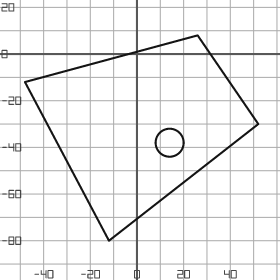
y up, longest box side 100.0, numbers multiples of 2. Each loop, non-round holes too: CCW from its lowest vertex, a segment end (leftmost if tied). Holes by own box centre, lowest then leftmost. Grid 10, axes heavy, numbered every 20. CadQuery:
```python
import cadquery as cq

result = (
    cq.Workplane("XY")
    .moveTo(-12.0, -80.0)
    .lineTo(52.0, -30.0)
    .lineTo(26.0, 8.0)
    .lineTo(-48.0, -12.0)
    .close()
    .moveTo(14.0, -38.0)
    .circle(6.0)
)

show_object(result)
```